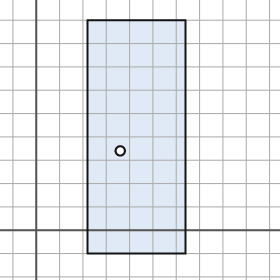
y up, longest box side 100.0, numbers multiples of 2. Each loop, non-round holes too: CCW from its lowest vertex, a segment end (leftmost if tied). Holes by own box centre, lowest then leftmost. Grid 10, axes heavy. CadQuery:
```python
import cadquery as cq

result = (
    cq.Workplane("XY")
    .moveTo(22.0, -10.0)
    .lineTo(64.0, -10.0)
    .lineTo(64.0, 90.0)
    .lineTo(22.0, 90.0)
    .close()
    .moveTo(36.0, 34.0)
    .circle(2.0)
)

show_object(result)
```